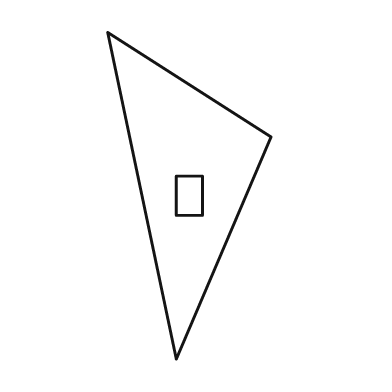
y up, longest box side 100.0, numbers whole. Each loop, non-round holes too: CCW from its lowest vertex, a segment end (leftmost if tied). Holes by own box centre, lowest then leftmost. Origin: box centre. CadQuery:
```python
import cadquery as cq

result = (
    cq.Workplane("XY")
    .moveTo(-4.0, -50.0)
    .lineTo(25.0, 18.0)
    .lineTo(-25.0, 50.0)
    .close()
    .moveTo(-4.0, -6.0)
    .lineTo(4.0, -6.0)
    .lineTo(4.0, 6.0)
    .lineTo(-4.0, 6.0)
    .close()
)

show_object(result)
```